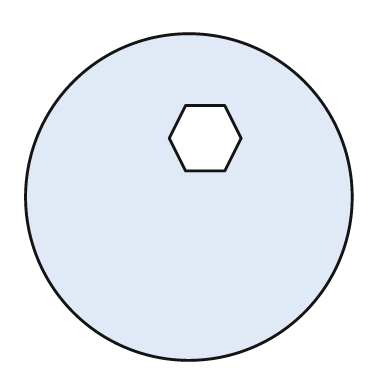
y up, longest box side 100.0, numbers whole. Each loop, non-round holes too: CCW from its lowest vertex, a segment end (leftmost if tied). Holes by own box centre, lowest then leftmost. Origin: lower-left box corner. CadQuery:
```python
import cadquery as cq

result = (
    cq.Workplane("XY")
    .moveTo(50.0, 50.0)
    .circle(50.0)
    .moveTo(49.0, 58.0)
    .lineTo(61.0, 58.0)
    .lineTo(66.0, 68.0)
    .lineTo(61.0, 78.0)
    .lineTo(49.0, 78.0)
    .lineTo(44.0, 68.0)
    .close()
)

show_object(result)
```